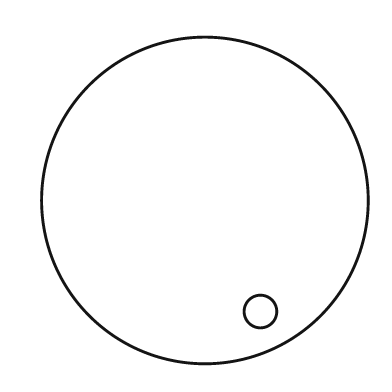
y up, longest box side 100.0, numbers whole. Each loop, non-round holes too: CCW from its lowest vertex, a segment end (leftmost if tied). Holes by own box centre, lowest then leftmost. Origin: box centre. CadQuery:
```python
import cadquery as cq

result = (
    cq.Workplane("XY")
    .moveTo(0.0, 0.0)
    .circle(50.0)
    .moveTo(17.0, -34.0)
    .circle(5.0)
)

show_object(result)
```